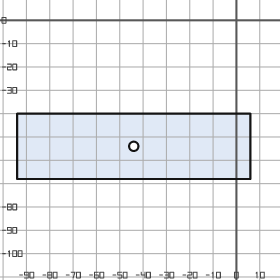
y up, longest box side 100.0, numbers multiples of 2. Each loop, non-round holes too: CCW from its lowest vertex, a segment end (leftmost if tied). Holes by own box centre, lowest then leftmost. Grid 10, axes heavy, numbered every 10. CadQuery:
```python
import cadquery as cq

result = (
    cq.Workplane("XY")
    .moveTo(-94.0, -68.0)
    .lineTo(6.0, -68.0)
    .lineTo(6.0, -40.0)
    .lineTo(-94.0, -40.0)
    .close()
    .moveTo(-44.0, -54.0)
    .circle(2.0)
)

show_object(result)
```